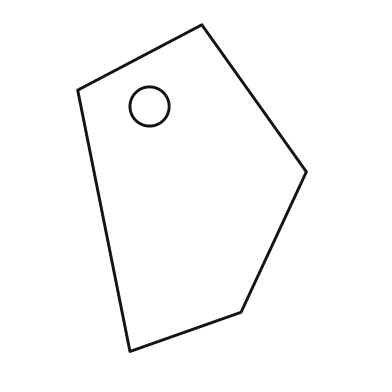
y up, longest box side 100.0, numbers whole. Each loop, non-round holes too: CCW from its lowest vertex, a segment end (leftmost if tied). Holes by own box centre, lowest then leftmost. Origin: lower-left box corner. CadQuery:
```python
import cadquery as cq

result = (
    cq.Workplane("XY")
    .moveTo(16.0, 0.0)
    .lineTo(50.0, 12.0)
    .lineTo(70.0, 55.0)
    .lineTo(38.0, 100.0)
    .lineTo(0.0, 80.0)
    .close()
    .moveTo(22.0, 75.0)
    .circle(6.0)
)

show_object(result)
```